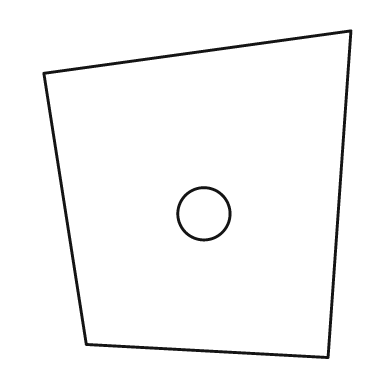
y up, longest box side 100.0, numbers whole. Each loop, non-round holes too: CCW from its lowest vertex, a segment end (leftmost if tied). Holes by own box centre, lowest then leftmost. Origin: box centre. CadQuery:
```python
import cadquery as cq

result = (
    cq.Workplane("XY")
    .moveTo(40.0, -50.0)
    .lineTo(47.0, 50.0)
    .lineTo(-47.0, 37.0)
    .lineTo(-34.0, -46.0)
    .close()
    .moveTo(2.0, -6.0)
    .circle(8.0)
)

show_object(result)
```